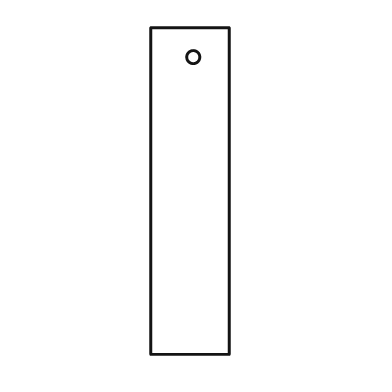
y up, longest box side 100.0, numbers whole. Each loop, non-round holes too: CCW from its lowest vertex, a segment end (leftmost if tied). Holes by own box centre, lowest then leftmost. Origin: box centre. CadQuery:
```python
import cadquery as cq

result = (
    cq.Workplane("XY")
    .moveTo(-12.0, -50.0)
    .lineTo(12.0, -50.0)
    .lineTo(12.0, 50.0)
    .lineTo(-12.0, 50.0)
    .close()
    .moveTo(1.0, 41.0)
    .circle(2.0)
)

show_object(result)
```